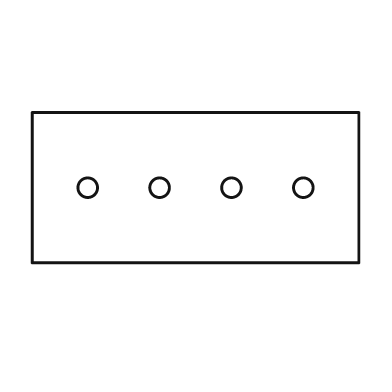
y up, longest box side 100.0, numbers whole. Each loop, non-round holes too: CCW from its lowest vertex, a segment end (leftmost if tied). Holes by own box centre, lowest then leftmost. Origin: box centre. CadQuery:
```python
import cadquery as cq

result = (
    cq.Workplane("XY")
    .moveTo(-50.0, -23.0)
    .lineTo(50.0, -23.0)
    .lineTo(50.0, 23.0)
    .lineTo(-50.0, 23.0)
    .close()
    .moveTo(-33.0, 0.0)
    .circle(3.0)
    .moveTo(-11.0, 0.0)
    .circle(3.0)
    .moveTo(11.0, 0.0)
    .circle(3.0)
    .moveTo(33.0, 0.0)
    .circle(3.0)
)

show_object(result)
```